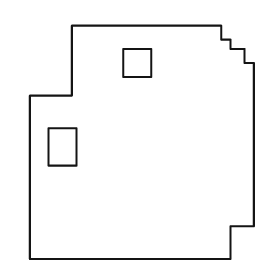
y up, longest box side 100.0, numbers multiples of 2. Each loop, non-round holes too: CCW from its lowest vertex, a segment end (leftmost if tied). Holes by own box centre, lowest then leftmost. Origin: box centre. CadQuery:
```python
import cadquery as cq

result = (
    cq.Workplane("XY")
    .moveTo(-48.0, -50.0)
    .lineTo(38.0, -50.0)
    .lineTo(38.0, -36.0)
    .lineTo(48.0, -36.0)
    .lineTo(48.0, 34.0)
    .lineTo(44.0, 34.0)
    .lineTo(44.0, 40.0)
    .lineTo(38.0, 40.0)
    .lineTo(38.0, 44.0)
    .lineTo(34.0, 44.0)
    .lineTo(34.0, 50.0)
    .lineTo(-30.0, 50.0)
    .lineTo(-30.0, 20.0)
    .lineTo(-48.0, 20.0)
    .close()
    .moveTo(-40.0, -10.0)
    .lineTo(-28.0, -10.0)
    .lineTo(-28.0, 6.0)
    .lineTo(-40.0, 6.0)
    .close()
    .moveTo(-8.0, 28.0)
    .lineTo(4.0, 28.0)
    .lineTo(4.0, 40.0)
    .lineTo(-8.0, 40.0)
    .close()
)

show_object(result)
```